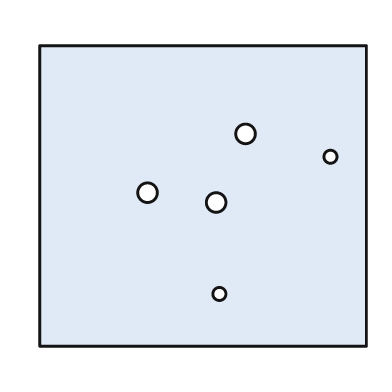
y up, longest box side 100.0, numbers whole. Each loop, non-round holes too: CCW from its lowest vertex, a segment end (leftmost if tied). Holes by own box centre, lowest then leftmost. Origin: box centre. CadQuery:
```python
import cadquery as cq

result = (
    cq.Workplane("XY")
    .moveTo(-50.0, -46.0)
    .lineTo(50.0, -46.0)
    .lineTo(50.0, 46.0)
    .lineTo(-50.0, 46.0)
    .close()
    .moveTo(5.0, -30.0)
    .circle(2.0)
    .moveTo(4.0, -2.0)
    .circle(3.0)
    .moveTo(-17.0, 1.0)
    .circle(3.0)
    .moveTo(39.0, 12.0)
    .circle(2.0)
    .moveTo(13.0, 19.0)
    .circle(3.0)
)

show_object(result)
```